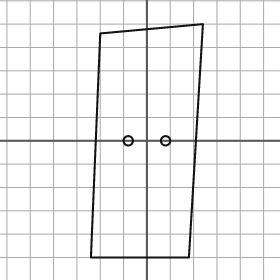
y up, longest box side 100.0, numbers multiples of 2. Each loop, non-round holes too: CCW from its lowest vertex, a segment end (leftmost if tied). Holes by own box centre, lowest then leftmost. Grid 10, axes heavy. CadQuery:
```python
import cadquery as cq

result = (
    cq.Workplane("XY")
    .moveTo(-24.0, -50.0)
    .lineTo(18.0, -50.0)
    .lineTo(24.0, 50.0)
    .lineTo(-20.0, 46.0)
    .close()
    .moveTo(-8.0, 0.0)
    .circle(2.0)
    .moveTo(8.0, 0.0)
    .circle(2.0)
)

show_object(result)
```